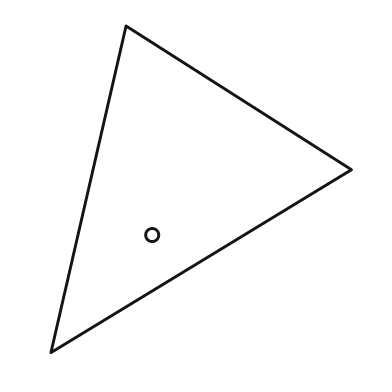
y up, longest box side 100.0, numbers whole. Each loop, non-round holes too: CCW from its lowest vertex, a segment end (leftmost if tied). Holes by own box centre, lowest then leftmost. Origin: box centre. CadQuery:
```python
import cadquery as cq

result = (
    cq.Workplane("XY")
    .moveTo(-46.0, -50.0)
    .lineTo(46.0, 6.0)
    .lineTo(-23.0, 50.0)
    .close()
    .moveTo(-15.0, -14.0)
    .circle(2.0)
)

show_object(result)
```